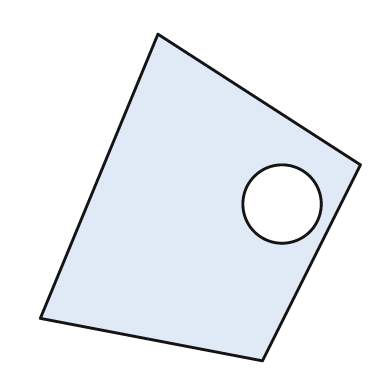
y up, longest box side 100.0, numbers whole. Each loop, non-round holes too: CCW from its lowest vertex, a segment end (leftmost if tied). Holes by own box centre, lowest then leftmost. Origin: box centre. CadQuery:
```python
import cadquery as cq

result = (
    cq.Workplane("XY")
    .moveTo(19.0, -50.0)
    .lineTo(49.0, 10.0)
    .lineTo(-13.0, 50.0)
    .lineTo(-49.0, -37.0)
    .close()
    .moveTo(25.0, -2.0)
    .circle(12.0)
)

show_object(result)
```